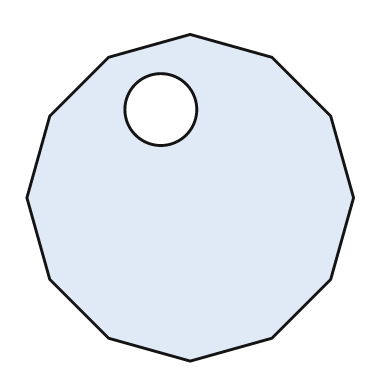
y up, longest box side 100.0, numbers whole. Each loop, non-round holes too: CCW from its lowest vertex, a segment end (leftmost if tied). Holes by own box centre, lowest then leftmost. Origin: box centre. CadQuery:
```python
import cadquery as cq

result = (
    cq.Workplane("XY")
    .moveTo(0.0, -50.0)
    .lineTo(25.0, -43.0)
    .lineTo(43.0, -25.0)
    .lineTo(50.0, 0.0)
    .lineTo(43.0, 25.0)
    .lineTo(25.0, 43.0)
    .lineTo(0.0, 50.0)
    .lineTo(-25.0, 43.0)
    .lineTo(-43.0, 25.0)
    .lineTo(-50.0, 0.0)
    .lineTo(-43.0, -25.0)
    .lineTo(-25.0, -43.0)
    .close()
    .moveTo(-9.0, 27.0)
    .circle(11.0)
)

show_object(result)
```